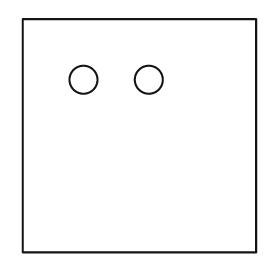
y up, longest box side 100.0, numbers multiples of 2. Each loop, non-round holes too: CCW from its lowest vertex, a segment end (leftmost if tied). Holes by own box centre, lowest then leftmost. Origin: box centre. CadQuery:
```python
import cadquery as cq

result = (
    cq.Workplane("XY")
    .moveTo(-50.0, -50.0)
    .lineTo(50.0, -50.0)
    .lineTo(50.0, 50.0)
    .lineTo(-50.0, 50.0)
    .close()
    .moveTo(-24.0, 24.0)
    .circle(6.0)
    .moveTo(4.0, 24.0)
    .circle(6.0)
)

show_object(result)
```